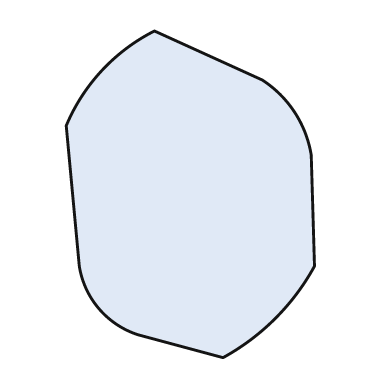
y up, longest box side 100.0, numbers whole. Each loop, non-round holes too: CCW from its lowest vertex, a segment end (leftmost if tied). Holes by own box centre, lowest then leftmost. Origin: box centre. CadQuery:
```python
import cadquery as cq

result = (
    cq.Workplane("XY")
    .moveTo(10.0, -50.0)
    .threePointArc((26.0, -38.0), (38.0, -22.0))
    .lineTo(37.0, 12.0)
    .threePointArc((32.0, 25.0), (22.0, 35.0))
    .lineTo(-11.0, 50.0)
    .threePointArc((-27.0, 38.0), (-38.0, 21.0))
    .lineTo(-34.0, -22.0)
    .threePointArc((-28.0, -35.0), (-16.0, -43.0))
    .close()
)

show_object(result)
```